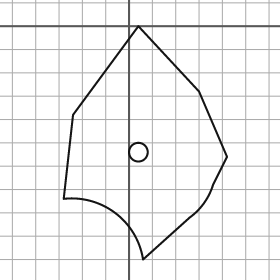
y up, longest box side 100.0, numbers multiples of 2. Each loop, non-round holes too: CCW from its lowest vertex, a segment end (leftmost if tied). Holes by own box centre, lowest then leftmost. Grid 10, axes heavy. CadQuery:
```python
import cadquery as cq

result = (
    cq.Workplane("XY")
    .moveTo(6.0, -100.0)
    .lineTo(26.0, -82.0)
    .threePointArc((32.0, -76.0), (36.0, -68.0))
    .lineTo(42.0, -56.0)
    .lineTo(30.0, -28.0)
    .lineTo(4.0, 0.0)
    .lineTo(-24.0, -38.0)
    .lineTo(-28.0, -74.0)
    .threePointArc((-6.0, -80.0), (6.0, -100.0))
    .close()
    .moveTo(4.0, -54.0)
    .circle(4.0)
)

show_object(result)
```